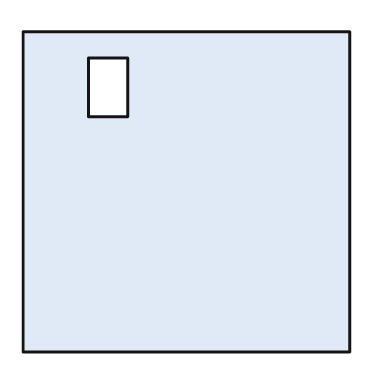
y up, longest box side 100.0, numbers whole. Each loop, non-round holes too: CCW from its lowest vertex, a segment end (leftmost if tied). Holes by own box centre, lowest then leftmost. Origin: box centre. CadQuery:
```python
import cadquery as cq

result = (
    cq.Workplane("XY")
    .moveTo(-50.0, -49.0)
    .lineTo(50.0, -49.0)
    .lineTo(50.0, 49.0)
    .lineTo(-50.0, 49.0)
    .close()
    .moveTo(-30.0, 23.0)
    .lineTo(-18.0, 23.0)
    .lineTo(-18.0, 41.0)
    .lineTo(-30.0, 41.0)
    .close()
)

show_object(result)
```